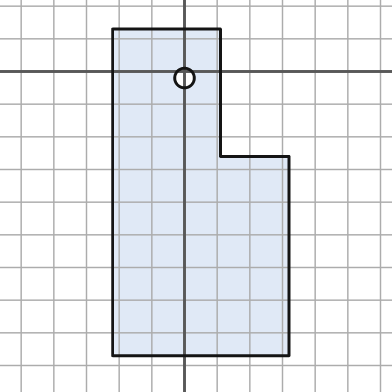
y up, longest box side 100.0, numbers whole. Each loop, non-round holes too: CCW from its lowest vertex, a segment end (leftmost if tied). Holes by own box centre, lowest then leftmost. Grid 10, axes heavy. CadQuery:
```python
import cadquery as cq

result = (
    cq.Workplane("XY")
    .moveTo(-22.0, -87.0)
    .lineTo(32.0, -87.0)
    .lineTo(32.0, -26.0)
    .lineTo(11.0, -26.0)
    .lineTo(11.0, 13.0)
    .lineTo(-22.0, 13.0)
    .close()
    .moveTo(0.0, -2.0)
    .circle(3.0)
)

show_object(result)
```